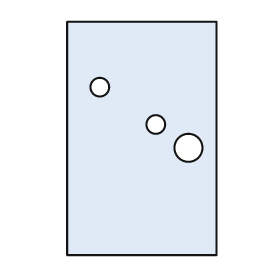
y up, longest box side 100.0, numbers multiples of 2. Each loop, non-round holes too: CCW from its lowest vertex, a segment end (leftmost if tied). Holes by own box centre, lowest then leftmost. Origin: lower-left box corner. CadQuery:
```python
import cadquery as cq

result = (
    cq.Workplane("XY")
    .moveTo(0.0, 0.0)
    .lineTo(64.0, 0.0)
    .lineTo(64.0, 100.0)
    .lineTo(0.0, 100.0)
    .close()
    .moveTo(52.0, 46.0)
    .circle(6.0)
    .moveTo(38.0, 56.0)
    .circle(4.0)
    .moveTo(14.0, 72.0)
    .circle(4.0)
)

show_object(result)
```